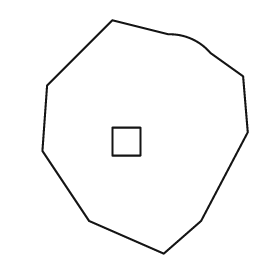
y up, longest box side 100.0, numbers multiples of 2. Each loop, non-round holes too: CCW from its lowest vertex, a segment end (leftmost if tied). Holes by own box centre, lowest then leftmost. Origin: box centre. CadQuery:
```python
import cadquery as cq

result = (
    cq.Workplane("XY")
    .moveTo(8.0, -50.0)
    .lineTo(24.0, -36.0)
    .lineTo(44.0, 2.0)
    .lineTo(42.0, 26.0)
    .lineTo(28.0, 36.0)
    .threePointArc((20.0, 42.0), (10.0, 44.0))
    .lineTo(-14.0, 50.0)
    .lineTo(-42.0, 22.0)
    .lineTo(-44.0, -6.0)
    .lineTo(-24.0, -36.0)
    .close()
    .moveTo(-14.0, -8.0)
    .lineTo(-2.0, -8.0)
    .lineTo(-2.0, 4.0)
    .lineTo(-14.0, 4.0)
    .close()
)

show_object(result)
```